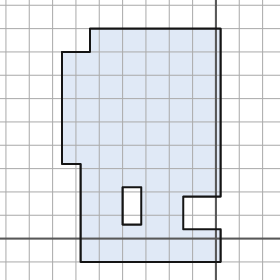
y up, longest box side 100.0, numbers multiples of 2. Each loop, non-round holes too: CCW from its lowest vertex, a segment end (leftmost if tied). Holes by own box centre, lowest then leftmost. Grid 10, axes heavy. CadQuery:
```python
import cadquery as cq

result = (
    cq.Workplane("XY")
    .moveTo(-58.0, -10.0)
    .lineTo(2.0, -10.0)
    .lineTo(2.0, 4.0)
    .lineTo(-14.0, 4.0)
    .lineTo(-14.0, 18.0)
    .lineTo(2.0, 18.0)
    .lineTo(2.0, 90.0)
    .lineTo(-54.0, 90.0)
    .lineTo(-54.0, 80.0)
    .lineTo(-66.0, 80.0)
    .lineTo(-66.0, 32.0)
    .lineTo(-58.0, 32.0)
    .close()
    .moveTo(-40.0, 6.0)
    .lineTo(-32.0, 6.0)
    .lineTo(-32.0, 22.0)
    .lineTo(-40.0, 22.0)
    .close()
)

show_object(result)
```